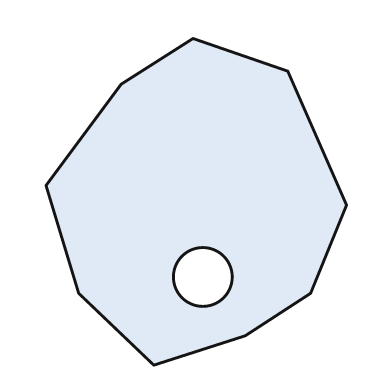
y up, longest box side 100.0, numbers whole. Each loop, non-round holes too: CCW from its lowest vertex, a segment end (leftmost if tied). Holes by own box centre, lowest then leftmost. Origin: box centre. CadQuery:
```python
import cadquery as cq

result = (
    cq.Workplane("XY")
    .moveTo(-13.0, -50.0)
    .lineTo(15.0, -41.0)
    .lineTo(35.0, -28.0)
    .lineTo(46.0, -1.0)
    .lineTo(28.0, 40.0)
    .lineTo(-1.0, 50.0)
    .lineTo(-23.0, 36.0)
    .lineTo(-46.0, 5.0)
    .lineTo(-36.0, -28.0)
    .close()
    .moveTo(2.0, -23.0)
    .circle(9.0)
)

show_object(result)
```